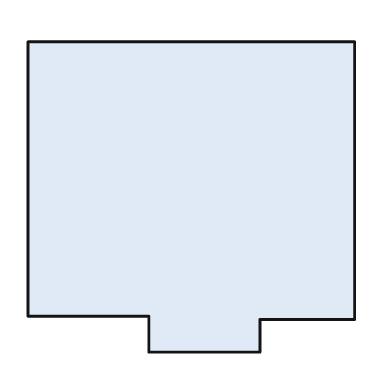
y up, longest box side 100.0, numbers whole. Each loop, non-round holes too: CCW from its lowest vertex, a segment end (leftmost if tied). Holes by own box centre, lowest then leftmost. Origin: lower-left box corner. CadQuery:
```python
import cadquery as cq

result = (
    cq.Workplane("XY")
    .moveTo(37.0, 0.0)
    .lineTo(71.0, 0.0)
    .lineTo(71.0, 10.0)
    .lineTo(100.0, 10.0)
    .lineTo(100.0, 95.0)
    .lineTo(0.0, 95.0)
    .lineTo(0.0, 11.0)
    .lineTo(37.0, 11.0)
    .close()
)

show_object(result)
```